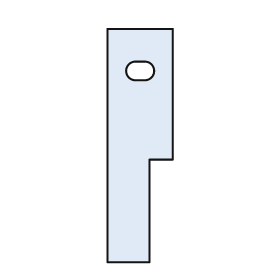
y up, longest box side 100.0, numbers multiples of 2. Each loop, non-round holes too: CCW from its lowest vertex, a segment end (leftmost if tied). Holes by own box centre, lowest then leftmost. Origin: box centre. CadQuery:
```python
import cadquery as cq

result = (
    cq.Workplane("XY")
    .moveTo(-14.0, -50.0)
    .lineTo(4.0, -50.0)
    .lineTo(4.0, -6.0)
    .lineTo(14.0, -6.0)
    .lineTo(14.0, 50.0)
    .lineTo(-14.0, 50.0)
    .close()
    .moveTo(-2.0, 28.0)
    .lineTo(2.0, 28.0)
    .threePointArc((6.0, 32.0), (2.0, 36.0))
    .lineTo(-2.0, 36.0)
    .threePointArc((-6.0, 32.0), (-2.0, 28.0))
    .close()
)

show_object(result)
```